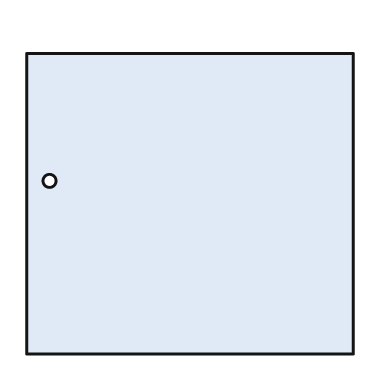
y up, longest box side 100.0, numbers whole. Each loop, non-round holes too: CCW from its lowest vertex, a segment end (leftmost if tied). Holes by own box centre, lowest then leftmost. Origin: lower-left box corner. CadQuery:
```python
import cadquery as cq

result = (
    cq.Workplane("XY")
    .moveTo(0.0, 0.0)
    .lineTo(100.0, 0.0)
    .lineTo(100.0, 92.0)
    .lineTo(0.0, 92.0)
    .close()
    .moveTo(7.0, 53.0)
    .circle(2.0)
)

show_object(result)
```